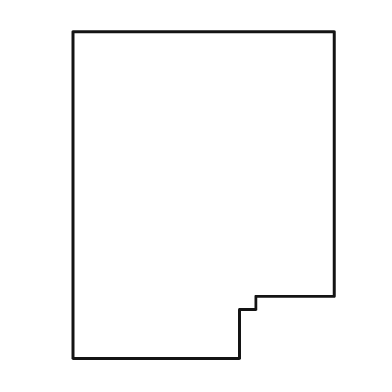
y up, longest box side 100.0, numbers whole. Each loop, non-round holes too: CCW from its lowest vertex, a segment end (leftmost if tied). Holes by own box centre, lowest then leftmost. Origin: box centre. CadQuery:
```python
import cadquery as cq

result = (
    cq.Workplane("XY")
    .moveTo(-40.0, -50.0)
    .lineTo(11.0, -50.0)
    .lineTo(11.0, -35.0)
    .lineTo(16.0, -35.0)
    .lineTo(16.0, -31.0)
    .lineTo(40.0, -31.0)
    .lineTo(40.0, 50.0)
    .lineTo(-40.0, 50.0)
    .close()
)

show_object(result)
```